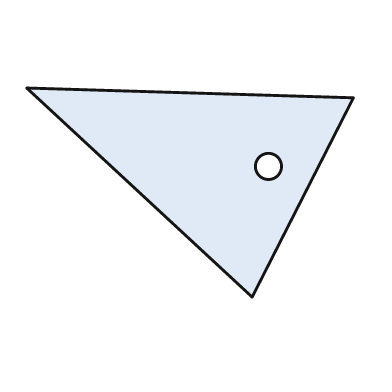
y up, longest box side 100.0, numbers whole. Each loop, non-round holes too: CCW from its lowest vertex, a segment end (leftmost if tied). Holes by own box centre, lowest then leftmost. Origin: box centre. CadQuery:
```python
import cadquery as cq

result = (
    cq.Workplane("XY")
    .moveTo(19.0, -32.0)
    .lineTo(50.0, 29.0)
    .lineTo(-50.0, 32.0)
    .close()
    .moveTo(24.0, 8.0)
    .circle(4.0)
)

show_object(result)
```